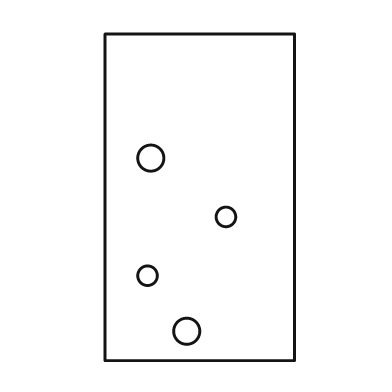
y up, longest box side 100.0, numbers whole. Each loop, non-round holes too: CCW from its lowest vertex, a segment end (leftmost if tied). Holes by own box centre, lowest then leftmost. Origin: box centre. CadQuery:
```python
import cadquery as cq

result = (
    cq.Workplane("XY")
    .moveTo(-29.0, -50.0)
    .lineTo(29.0, -50.0)
    .lineTo(29.0, 50.0)
    .lineTo(-29.0, 50.0)
    .close()
    .moveTo(-4.0, -41.0)
    .circle(4.0)
    .moveTo(-16.0, -24.0)
    .circle(3.0)
    .moveTo(8.0, -6.0)
    .circle(3.0)
    .moveTo(-15.0, 12.0)
    .circle(4.0)
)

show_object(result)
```